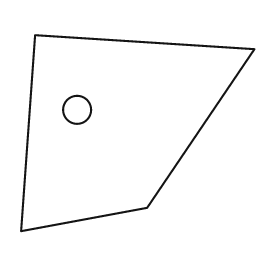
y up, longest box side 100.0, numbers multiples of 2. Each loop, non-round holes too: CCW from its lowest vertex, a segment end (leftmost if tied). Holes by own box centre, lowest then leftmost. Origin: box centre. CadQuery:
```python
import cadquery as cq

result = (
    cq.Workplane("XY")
    .moveTo(-50.0, -42.0)
    .lineTo(4.0, -32.0)
    .lineTo(50.0, 36.0)
    .lineTo(-44.0, 42.0)
    .close()
    .moveTo(-26.0, 10.0)
    .circle(6.0)
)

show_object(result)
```